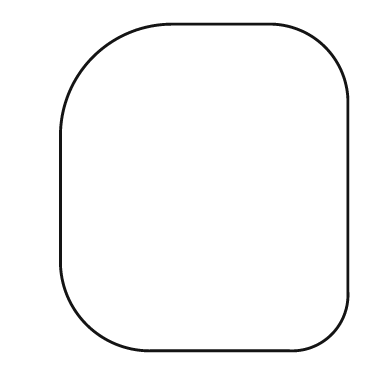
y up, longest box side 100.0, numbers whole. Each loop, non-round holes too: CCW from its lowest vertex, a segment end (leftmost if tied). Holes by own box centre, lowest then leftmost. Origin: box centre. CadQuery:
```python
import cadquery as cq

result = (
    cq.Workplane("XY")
    .moveTo(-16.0, -50.0)
    .lineTo(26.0, -50.0)
    .threePointArc((39.0, -45.0), (44.0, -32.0))
    .lineTo(44.0, 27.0)
    .threePointArc((37.0, 43.0), (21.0, 50.0))
    .lineTo(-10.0, 50.0)
    .threePointArc((-34.0, 40.0), (-44.0, 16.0))
    .lineTo(-44.0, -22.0)
    .threePointArc((-36.0, -42.0), (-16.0, -50.0))
    .close()
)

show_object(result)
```